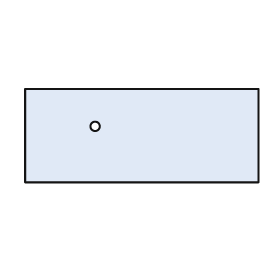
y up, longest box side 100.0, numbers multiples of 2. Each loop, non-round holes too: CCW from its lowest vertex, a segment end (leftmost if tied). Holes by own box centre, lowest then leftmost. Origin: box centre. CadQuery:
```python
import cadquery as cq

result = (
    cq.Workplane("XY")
    .moveTo(-50.0, -20.0)
    .lineTo(50.0, -20.0)
    .lineTo(50.0, 20.0)
    .lineTo(-50.0, 20.0)
    .close()
    .moveTo(-20.0, 4.0)
    .circle(2.0)
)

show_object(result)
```